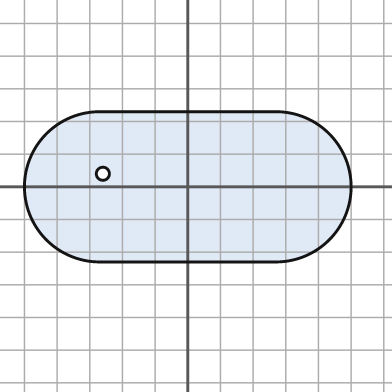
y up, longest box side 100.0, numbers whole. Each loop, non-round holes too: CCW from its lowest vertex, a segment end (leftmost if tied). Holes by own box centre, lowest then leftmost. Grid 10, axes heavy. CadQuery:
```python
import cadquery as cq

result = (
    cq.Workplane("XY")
    .moveTo(-27.0, -23.0)
    .lineTo(27.0, -23.0)
    .threePointArc((50.0, 0.0), (27.0, 23.0))
    .lineTo(-27.0, 23.0)
    .threePointArc((-50.0, 0.0), (-27.0, -23.0))
    .close()
    .moveTo(-26.0, 4.0)
    .circle(2.0)
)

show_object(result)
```